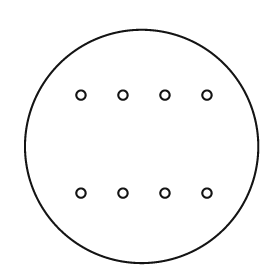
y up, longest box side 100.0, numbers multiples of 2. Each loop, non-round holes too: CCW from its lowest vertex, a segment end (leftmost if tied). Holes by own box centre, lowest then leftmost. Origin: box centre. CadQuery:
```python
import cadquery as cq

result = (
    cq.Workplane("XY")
    .moveTo(0.0, 0.0)
    .circle(50.0)
    .moveTo(-26.0, -20.0)
    .circle(2.0)
    .moveTo(-8.0, -20.0)
    .circle(2.0)
    .moveTo(10.0, -20.0)
    .circle(2.0)
    .moveTo(28.0, -20.0)
    .circle(2.0)
    .moveTo(-26.0, 22.0)
    .circle(2.0)
    .moveTo(-8.0, 22.0)
    .circle(2.0)
    .moveTo(10.0, 22.0)
    .circle(2.0)
    .moveTo(28.0, 22.0)
    .circle(2.0)
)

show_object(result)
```